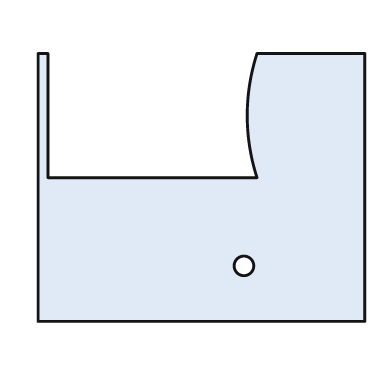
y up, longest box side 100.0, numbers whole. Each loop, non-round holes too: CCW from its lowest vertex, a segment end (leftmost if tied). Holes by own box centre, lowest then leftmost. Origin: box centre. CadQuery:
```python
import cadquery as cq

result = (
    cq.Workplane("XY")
    .moveTo(-50.0, -41.0)
    .lineTo(50.0, -41.0)
    .lineTo(50.0, 41.0)
    .lineTo(17.0, 41.0)
    .threePointArc((14.0, 22.0), (17.0, 3.0))
    .lineTo(-47.0, 3.0)
    .lineTo(-47.0, 41.0)
    .lineTo(-50.0, 41.0)
    .close()
    .moveTo(13.0, -24.0)
    .circle(3.0)
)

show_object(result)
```